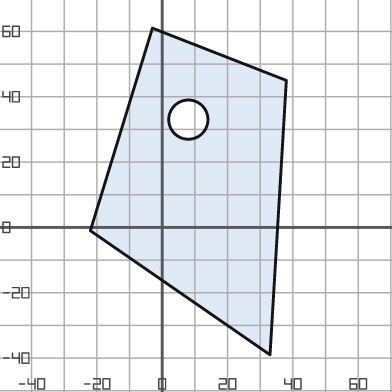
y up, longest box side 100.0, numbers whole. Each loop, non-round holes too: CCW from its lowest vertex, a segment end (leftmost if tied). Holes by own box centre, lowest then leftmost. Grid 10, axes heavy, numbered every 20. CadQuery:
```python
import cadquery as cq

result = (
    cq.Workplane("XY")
    .moveTo(33.0, -39.0)
    .lineTo(38.0, 45.0)
    .lineTo(-3.0, 61.0)
    .lineTo(-22.0, -1.0)
    .close()
    .moveTo(8.0, 33.0)
    .circle(6.0)
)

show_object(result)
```